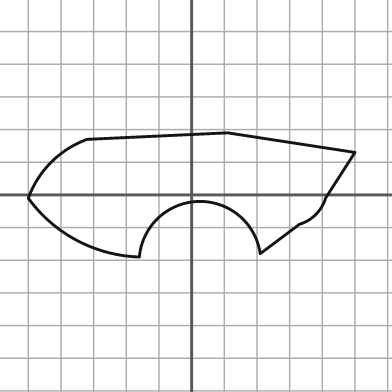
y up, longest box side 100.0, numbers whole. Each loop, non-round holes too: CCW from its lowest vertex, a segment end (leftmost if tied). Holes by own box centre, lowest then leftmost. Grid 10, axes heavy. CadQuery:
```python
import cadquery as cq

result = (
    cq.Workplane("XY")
    .moveTo(-16.0, -19.0)
    .threePointArc((2.0, -2.0), (21.0, -18.0))
    .lineTo(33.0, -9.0)
    .threePointArc((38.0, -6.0), (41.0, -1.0))
    .lineTo(50.0, 13.0)
    .lineTo(11.0, 19.0)
    .lineTo(-32.0, 17.0)
    .threePointArc((-43.0, 10.0), (-50.0, -1.0))
    .threePointArc((-35.0, -14.0), (-16.0, -19.0))
    .close()
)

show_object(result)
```